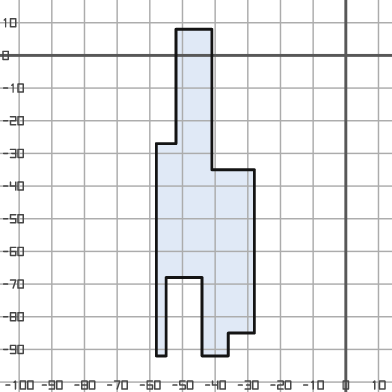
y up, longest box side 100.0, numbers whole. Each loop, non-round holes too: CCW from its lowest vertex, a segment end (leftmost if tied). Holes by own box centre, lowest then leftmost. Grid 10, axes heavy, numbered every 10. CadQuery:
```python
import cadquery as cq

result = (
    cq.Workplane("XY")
    .moveTo(-58.0, -92.0)
    .lineTo(-55.0, -92.0)
    .lineTo(-55.0, -68.0)
    .lineTo(-44.0, -68.0)
    .lineTo(-44.0, -92.0)
    .lineTo(-36.0, -92.0)
    .lineTo(-36.0, -85.0)
    .lineTo(-28.0, -85.0)
    .lineTo(-28.0, -35.0)
    .lineTo(-41.0, -35.0)
    .lineTo(-41.0, 8.0)
    .lineTo(-52.0, 8.0)
    .lineTo(-52.0, -27.0)
    .lineTo(-58.0, -27.0)
    .close()
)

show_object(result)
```